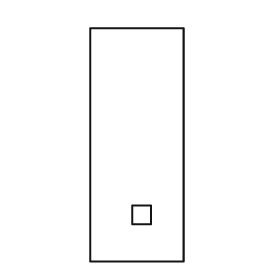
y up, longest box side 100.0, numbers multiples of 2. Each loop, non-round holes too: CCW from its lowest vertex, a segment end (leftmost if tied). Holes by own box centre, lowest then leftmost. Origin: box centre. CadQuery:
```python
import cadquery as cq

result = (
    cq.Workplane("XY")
    .moveTo(-20.0, -50.0)
    .lineTo(20.0, -50.0)
    .lineTo(20.0, 50.0)
    .lineTo(-20.0, 50.0)
    .close()
    .moveTo(-2.0, -34.0)
    .lineTo(6.0, -34.0)
    .lineTo(6.0, -26.0)
    .lineTo(-2.0, -26.0)
    .close()
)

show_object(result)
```